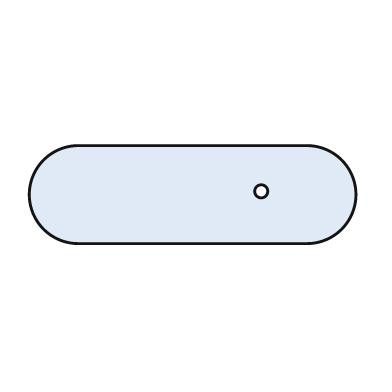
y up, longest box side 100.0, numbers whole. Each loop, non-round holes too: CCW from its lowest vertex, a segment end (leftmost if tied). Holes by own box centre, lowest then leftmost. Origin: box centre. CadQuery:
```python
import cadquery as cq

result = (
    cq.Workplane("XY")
    .moveTo(-35.0, -15.0)
    .lineTo(35.0, -15.0)
    .threePointArc((50.0, 0.0), (35.0, 15.0))
    .lineTo(-35.0, 15.0)
    .threePointArc((-50.0, 0.0), (-35.0, -15.0))
    .close()
    .moveTo(21.0, 1.0)
    .circle(2.0)
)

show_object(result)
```